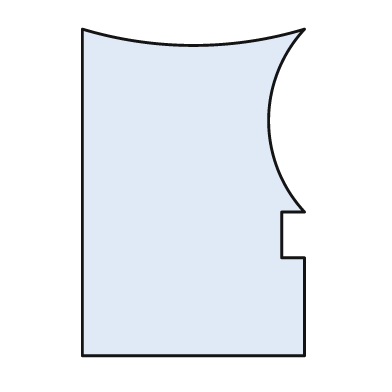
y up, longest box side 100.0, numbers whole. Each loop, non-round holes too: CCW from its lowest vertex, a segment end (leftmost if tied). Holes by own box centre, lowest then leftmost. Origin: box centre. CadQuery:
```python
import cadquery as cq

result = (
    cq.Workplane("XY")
    .moveTo(-34.0, -50.0)
    .lineTo(34.0, -50.0)
    .lineTo(34.0, -20.0)
    .lineTo(27.0, -20.0)
    .lineTo(27.0, -6.0)
    .lineTo(34.0, -6.0)
    .threePointArc((23.0, 22.0), (34.0, 50.0))
    .threePointArc((0.0, 45.0), (-34.0, 50.0))
    .close()
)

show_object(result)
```